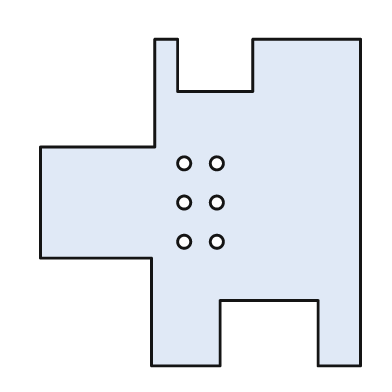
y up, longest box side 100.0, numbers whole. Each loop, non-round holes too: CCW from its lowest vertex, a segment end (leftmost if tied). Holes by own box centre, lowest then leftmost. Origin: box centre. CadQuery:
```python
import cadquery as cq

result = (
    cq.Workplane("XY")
    .moveTo(-15.0, -50.0)
    .lineTo(6.0, -50.0)
    .lineTo(6.0, -30.0)
    .lineTo(36.0, -30.0)
    .lineTo(36.0, -50.0)
    .lineTo(49.0, -50.0)
    .lineTo(49.0, 50.0)
    .lineTo(16.0, 50.0)
    .lineTo(16.0, 34.0)
    .lineTo(-7.0, 34.0)
    .lineTo(-7.0, 50.0)
    .lineTo(-14.0, 50.0)
    .lineTo(-14.0, 17.0)
    .lineTo(-49.0, 17.0)
    .lineTo(-49.0, -17.0)
    .lineTo(-15.0, -17.0)
    .close()
    .moveTo(-5.0, -12.0)
    .circle(2.0)
    .moveTo(5.0, -12.0)
    .circle(2.0)
    .moveTo(-5.0, 0.0)
    .circle(2.0)
    .moveTo(5.0, 0.0)
    .circle(2.0)
    .moveTo(-5.0, 12.0)
    .circle(2.0)
    .moveTo(5.0, 12.0)
    .circle(2.0)
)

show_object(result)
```